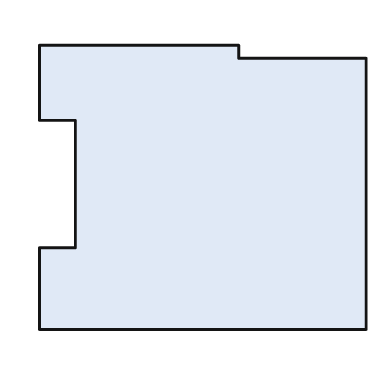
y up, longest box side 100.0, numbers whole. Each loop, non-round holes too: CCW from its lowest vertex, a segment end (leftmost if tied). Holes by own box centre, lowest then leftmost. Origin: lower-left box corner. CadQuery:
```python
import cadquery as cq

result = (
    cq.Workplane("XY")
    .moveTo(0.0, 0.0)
    .lineTo(100.0, 0.0)
    .lineTo(100.0, 83.0)
    .lineTo(61.0, 83.0)
    .lineTo(61.0, 87.0)
    .lineTo(0.0, 87.0)
    .lineTo(0.0, 64.0)
    .lineTo(11.0, 64.0)
    .lineTo(11.0, 25.0)
    .lineTo(0.0, 25.0)
    .close()
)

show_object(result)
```